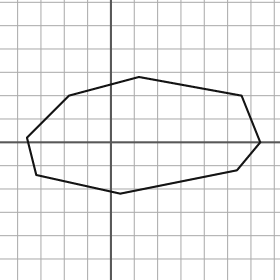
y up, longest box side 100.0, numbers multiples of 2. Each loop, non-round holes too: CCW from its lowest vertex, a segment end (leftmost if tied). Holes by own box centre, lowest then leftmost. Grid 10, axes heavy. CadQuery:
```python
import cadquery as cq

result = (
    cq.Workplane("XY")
    .moveTo(4.0, -22.0)
    .lineTo(54.0, -12.0)
    .lineTo(64.0, 0.0)
    .lineTo(56.0, 20.0)
    .lineTo(12.0, 28.0)
    .lineTo(-18.0, 20.0)
    .lineTo(-36.0, 2.0)
    .lineTo(-32.0, -14.0)
    .close()
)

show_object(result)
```